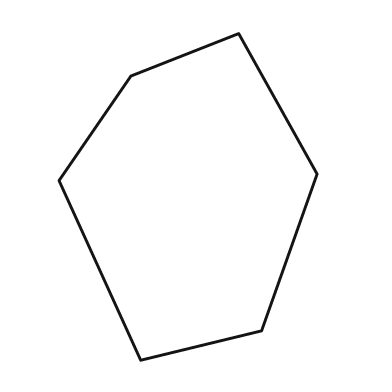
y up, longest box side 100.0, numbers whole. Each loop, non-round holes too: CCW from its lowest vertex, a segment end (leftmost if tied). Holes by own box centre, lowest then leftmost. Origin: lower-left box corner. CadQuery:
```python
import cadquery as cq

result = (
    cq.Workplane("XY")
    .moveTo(25.0, 0.0)
    .lineTo(62.0, 9.0)
    .lineTo(79.0, 57.0)
    .lineTo(55.0, 100.0)
    .lineTo(22.0, 87.0)
    .lineTo(0.0, 55.0)
    .close()
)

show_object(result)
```